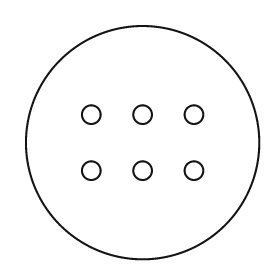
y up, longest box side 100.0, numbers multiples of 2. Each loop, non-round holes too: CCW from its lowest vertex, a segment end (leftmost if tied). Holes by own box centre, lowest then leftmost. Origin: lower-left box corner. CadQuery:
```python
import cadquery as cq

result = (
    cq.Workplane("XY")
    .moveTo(50.0, 50.0)
    .circle(50.0)
    .moveTo(28.0, 38.0)
    .circle(4.0)
    .moveTo(50.0, 38.0)
    .circle(4.0)
    .moveTo(72.0, 38.0)
    .circle(4.0)
    .moveTo(28.0, 62.0)
    .circle(4.0)
    .moveTo(50.0, 62.0)
    .circle(4.0)
    .moveTo(72.0, 62.0)
    .circle(4.0)
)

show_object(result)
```